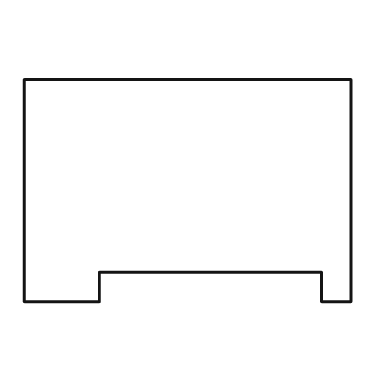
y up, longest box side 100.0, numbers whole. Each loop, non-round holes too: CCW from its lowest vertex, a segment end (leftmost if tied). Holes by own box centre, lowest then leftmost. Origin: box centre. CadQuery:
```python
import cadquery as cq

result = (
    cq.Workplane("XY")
    .moveTo(-50.0, -34.0)
    .lineTo(-27.0, -34.0)
    .lineTo(-27.0, -25.0)
    .lineTo(41.0, -25.0)
    .lineTo(41.0, -34.0)
    .lineTo(50.0, -34.0)
    .lineTo(50.0, 34.0)
    .lineTo(-50.0, 34.0)
    .close()
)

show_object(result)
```